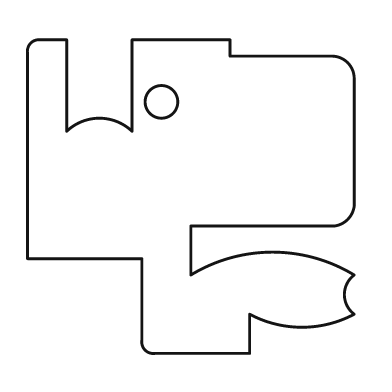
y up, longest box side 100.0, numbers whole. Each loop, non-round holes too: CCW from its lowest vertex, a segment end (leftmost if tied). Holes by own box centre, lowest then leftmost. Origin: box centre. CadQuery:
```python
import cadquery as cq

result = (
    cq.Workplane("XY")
    .moveTo(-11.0, -48.0)
    .lineTo(18.0, -48.0)
    .lineTo(18.0, -36.0)
    .threePointArc((34.0, -40.0), (50.0, -36.0))
    .threePointArc((47.0, -30.0), (50.0, -24.0))
    .threePointArc((25.0, -17.0), (0.0, -24.0))
    .lineTo(0.0, -9.0)
    .lineTo(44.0, -9.0)
    .threePointArc((48.0, -7.0), (50.0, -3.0))
    .lineTo(50.0, 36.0)
    .threePointArc((48.0, 41.0), (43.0, 43.0))
    .lineTo(12.0, 43.0)
    .lineTo(12.0, 48.0)
    .lineTo(-18.0, 48.0)
    .lineTo(-18.0, 20.0)
    .threePointArc((-28.0, 24.0), (-38.0, 20.0))
    .lineTo(-38.0, 48.0)
    .lineTo(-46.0, 48.0)
    .threePointArc((-49.0, 47.0), (-50.0, 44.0))
    .lineTo(-50.0, -19.0)
    .lineTo(-15.0, -19.0)
    .lineTo(-15.0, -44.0)
    .threePointArc((-14.0, -47.0), (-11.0, -48.0))
    .close()
    .moveTo(-9.0, 29.0)
    .circle(5.0)
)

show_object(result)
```